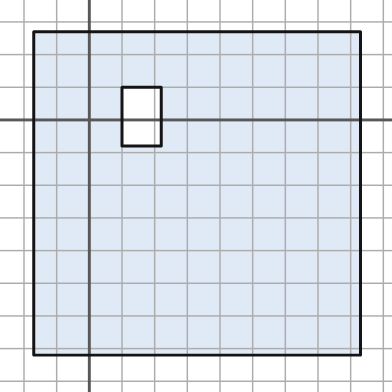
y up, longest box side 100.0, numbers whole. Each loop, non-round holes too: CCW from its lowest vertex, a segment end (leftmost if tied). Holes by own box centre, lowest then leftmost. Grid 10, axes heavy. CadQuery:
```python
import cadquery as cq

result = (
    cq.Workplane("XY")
    .moveTo(-17.0, -72.0)
    .lineTo(83.0, -72.0)
    .lineTo(83.0, 27.0)
    .lineTo(-17.0, 27.0)
    .close()
    .moveTo(10.0, -8.0)
    .lineTo(22.0, -8.0)
    .lineTo(22.0, 10.0)
    .lineTo(10.0, 10.0)
    .close()
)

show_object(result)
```